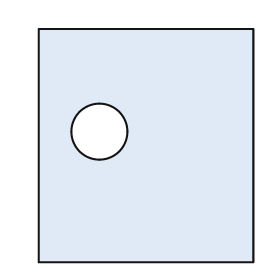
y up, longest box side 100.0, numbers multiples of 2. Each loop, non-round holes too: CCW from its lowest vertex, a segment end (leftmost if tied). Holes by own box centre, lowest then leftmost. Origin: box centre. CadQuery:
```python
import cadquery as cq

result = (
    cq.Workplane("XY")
    .moveTo(-46.0, -50.0)
    .lineTo(46.0, -50.0)
    .lineTo(46.0, 50.0)
    .lineTo(-46.0, 50.0)
    .close()
    .moveTo(-20.0, 6.0)
    .circle(12.0)
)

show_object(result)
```